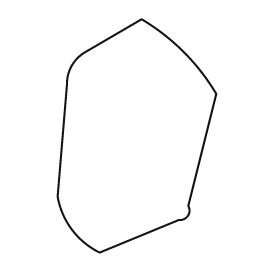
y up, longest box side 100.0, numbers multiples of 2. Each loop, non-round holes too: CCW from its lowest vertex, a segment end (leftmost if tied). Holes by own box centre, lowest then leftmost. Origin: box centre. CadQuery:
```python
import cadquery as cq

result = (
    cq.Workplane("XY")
    .moveTo(-16.0, -50.0)
    .lineTo(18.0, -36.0)
    .threePointArc((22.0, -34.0), (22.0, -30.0))
    .lineTo(34.0, 18.0)
    .threePointArc((20.0, 36.0), (2.0, 50.0))
    .lineTo(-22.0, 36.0)
    .threePointArc((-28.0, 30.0), (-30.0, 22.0))
    .lineTo(-34.0, -26.0)
    .threePointArc((-28.0, -40.0), (-16.0, -50.0))
    .close()
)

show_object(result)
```